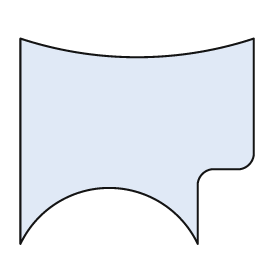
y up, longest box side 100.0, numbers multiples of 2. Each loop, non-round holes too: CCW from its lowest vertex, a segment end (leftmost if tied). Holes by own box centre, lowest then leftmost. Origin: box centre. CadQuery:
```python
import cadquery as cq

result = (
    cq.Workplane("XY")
    .moveTo(-50.0, -44.0)
    .threePointArc((-12.0, -20.0), (26.0, -44.0))
    .lineTo(26.0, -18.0)
    .threePointArc((28.0, -14.0), (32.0, -12.0))
    .lineTo(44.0, -12.0)
    .threePointArc((48.0, -10.0), (50.0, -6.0))
    .lineTo(50.0, 44.0)
    .threePointArc((0.0, 36.0), (-50.0, 44.0))
    .close()
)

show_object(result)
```